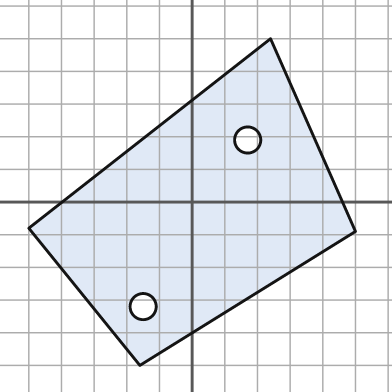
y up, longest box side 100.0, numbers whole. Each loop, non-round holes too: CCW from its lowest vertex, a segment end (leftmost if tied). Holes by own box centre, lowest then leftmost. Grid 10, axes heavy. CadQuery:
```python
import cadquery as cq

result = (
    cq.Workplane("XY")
    .moveTo(-16.0, -50.0)
    .lineTo(50.0, -9.0)
    .lineTo(24.0, 50.0)
    .lineTo(-50.0, -8.0)
    .close()
    .moveTo(-15.0, -32.0)
    .circle(4.0)
    .moveTo(17.0, 19.0)
    .circle(4.0)
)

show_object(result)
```